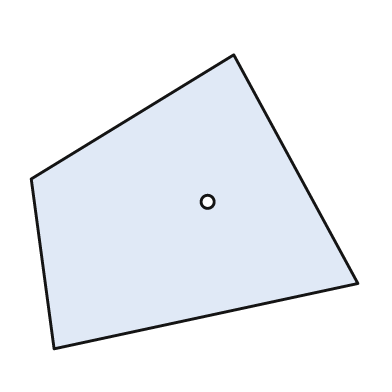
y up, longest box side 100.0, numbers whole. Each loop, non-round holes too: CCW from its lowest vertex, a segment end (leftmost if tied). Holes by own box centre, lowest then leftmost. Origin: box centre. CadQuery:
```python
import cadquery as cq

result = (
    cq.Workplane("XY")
    .moveTo(-43.0, -45.0)
    .lineTo(50.0, -25.0)
    .lineTo(12.0, 45.0)
    .lineTo(-50.0, 7.0)
    .close()
    .moveTo(4.0, 0.0)
    .circle(2.0)
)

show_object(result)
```